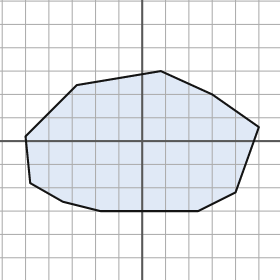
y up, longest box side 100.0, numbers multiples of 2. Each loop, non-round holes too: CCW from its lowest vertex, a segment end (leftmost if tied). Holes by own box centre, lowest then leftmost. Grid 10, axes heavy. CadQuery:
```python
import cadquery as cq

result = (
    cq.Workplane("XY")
    .moveTo(-18.0, -30.0)
    .lineTo(24.0, -30.0)
    .lineTo(40.0, -22.0)
    .lineTo(50.0, 6.0)
    .lineTo(30.0, 20.0)
    .lineTo(8.0, 30.0)
    .lineTo(-28.0, 24.0)
    .lineTo(-50.0, 2.0)
    .lineTo(-48.0, -18.0)
    .lineTo(-34.0, -26.0)
    .close()
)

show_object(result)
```